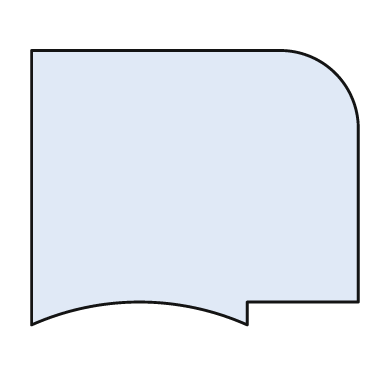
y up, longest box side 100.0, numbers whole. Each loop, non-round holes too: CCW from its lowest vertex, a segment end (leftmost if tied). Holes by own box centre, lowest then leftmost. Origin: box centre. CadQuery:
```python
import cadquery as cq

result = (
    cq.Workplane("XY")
    .moveTo(-50.0, -42.0)
    .threePointArc((-17.0, -35.0), (16.0, -42.0))
    .lineTo(16.0, -35.0)
    .lineTo(50.0, -35.0)
    .lineTo(50.0, 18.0)
    .threePointArc((43.0, 35.0), (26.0, 42.0))
    .lineTo(-50.0, 42.0)
    .close()
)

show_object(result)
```